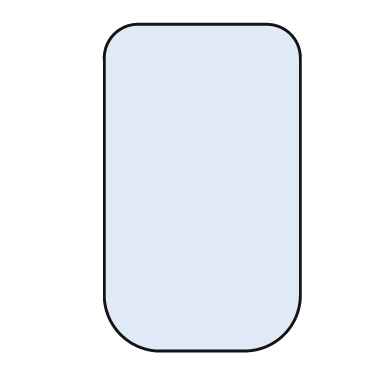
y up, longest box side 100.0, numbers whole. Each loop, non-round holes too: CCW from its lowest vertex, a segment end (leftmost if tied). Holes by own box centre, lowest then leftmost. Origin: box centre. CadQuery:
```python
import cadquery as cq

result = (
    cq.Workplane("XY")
    .moveTo(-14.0, -50.0)
    .lineTo(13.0, -50.0)
    .threePointArc((25.0, -45.0), (30.0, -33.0))
    .lineTo(30.0, 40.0)
    .threePointArc((27.0, 47.0), (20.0, 50.0))
    .lineTo(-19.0, 50.0)
    .threePointArc((-27.0, 47.0), (-30.0, 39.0))
    .lineTo(-30.0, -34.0)
    .threePointArc((-25.0, -45.0), (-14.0, -50.0))
    .close()
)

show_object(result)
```